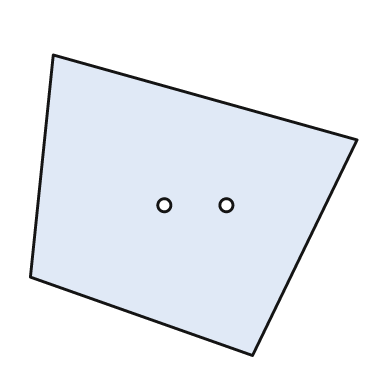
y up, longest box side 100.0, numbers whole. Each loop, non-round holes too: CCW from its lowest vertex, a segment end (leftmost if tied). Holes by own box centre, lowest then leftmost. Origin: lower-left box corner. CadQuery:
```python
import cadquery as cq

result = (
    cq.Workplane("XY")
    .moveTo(68.0, 0.0)
    .lineTo(100.0, 66.0)
    .lineTo(7.0, 92.0)
    .lineTo(0.0, 24.0)
    .close()
    .moveTo(41.0, 46.0)
    .circle(2.0)
    .moveTo(60.0, 46.0)
    .circle(2.0)
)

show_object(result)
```